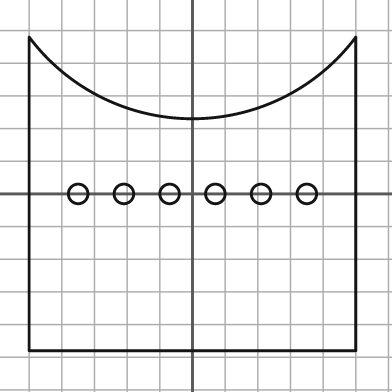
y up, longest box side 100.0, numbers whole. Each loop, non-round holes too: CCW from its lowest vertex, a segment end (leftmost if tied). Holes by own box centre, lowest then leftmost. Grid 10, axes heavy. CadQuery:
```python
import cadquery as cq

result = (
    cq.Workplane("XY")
    .moveTo(-50.0, -48.0)
    .lineTo(50.0, -48.0)
    .lineTo(50.0, 48.0)
    .threePointArc((0.0, 23.0), (-50.0, 48.0))
    .close()
    .moveTo(-35.0, 0.0)
    .circle(3.0)
    .moveTo(-21.0, 0.0)
    .circle(3.0)
    .moveTo(-7.0, 0.0)
    .circle(3.0)
    .moveTo(7.0, 0.0)
    .circle(3.0)
    .moveTo(21.0, 0.0)
    .circle(3.0)
    .moveTo(35.0, 0.0)
    .circle(3.0)
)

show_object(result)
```